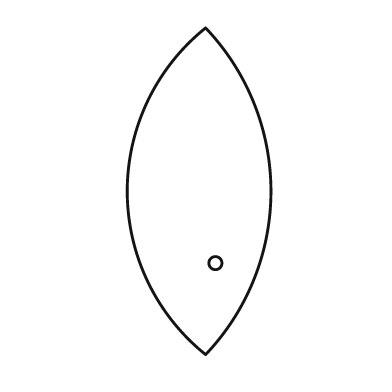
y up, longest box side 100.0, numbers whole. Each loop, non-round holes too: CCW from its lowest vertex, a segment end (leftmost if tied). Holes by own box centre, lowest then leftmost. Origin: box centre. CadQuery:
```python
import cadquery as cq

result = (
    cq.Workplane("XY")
    .moveTo(2.0, -50.0)
    .threePointArc((22.0, 0.0), (2.0, 50.0))
    .threePointArc((-22.0, 0.0), (2.0, -50.0))
    .close()
    .moveTo(5.0, -22.0)
    .circle(2.0)
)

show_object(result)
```